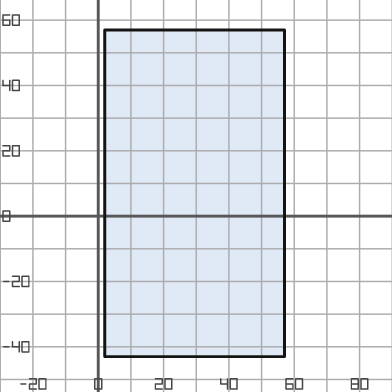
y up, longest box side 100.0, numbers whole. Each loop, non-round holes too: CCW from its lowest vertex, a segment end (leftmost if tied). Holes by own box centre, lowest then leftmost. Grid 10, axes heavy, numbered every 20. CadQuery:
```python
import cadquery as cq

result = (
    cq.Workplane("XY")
    .moveTo(2.0, -43.0)
    .lineTo(57.0, -43.0)
    .lineTo(57.0, 57.0)
    .lineTo(2.0, 57.0)
    .close()
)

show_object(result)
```